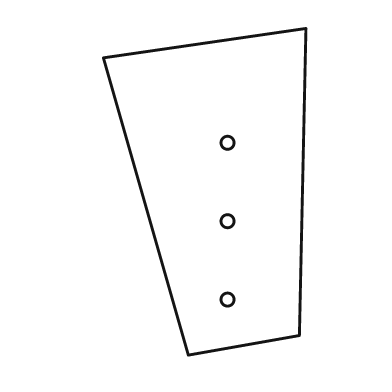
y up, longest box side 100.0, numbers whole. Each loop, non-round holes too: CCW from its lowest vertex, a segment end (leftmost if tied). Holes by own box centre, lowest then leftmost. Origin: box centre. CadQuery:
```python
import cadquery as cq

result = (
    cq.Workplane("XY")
    .moveTo(-5.0, -50.0)
    .lineTo(29.0, -44.0)
    .lineTo(31.0, 50.0)
    .lineTo(-31.0, 41.0)
    .close()
    .moveTo(7.0, -33.0)
    .circle(2.0)
    .moveTo(7.0, -9.0)
    .circle(2.0)
    .moveTo(7.0, 15.0)
    .circle(2.0)
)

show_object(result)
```